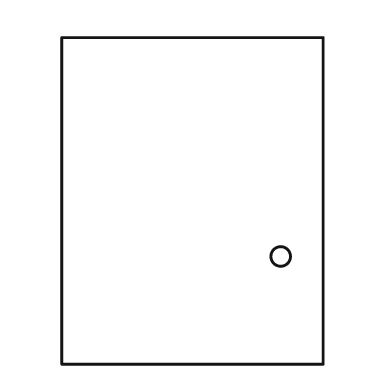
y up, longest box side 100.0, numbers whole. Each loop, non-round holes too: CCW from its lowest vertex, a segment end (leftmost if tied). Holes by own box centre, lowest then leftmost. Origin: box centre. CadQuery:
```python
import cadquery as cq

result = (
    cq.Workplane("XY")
    .moveTo(-40.0, -50.0)
    .lineTo(40.0, -50.0)
    .lineTo(40.0, 50.0)
    .lineTo(-40.0, 50.0)
    .close()
    .moveTo(27.0, -17.0)
    .circle(3.0)
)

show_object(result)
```